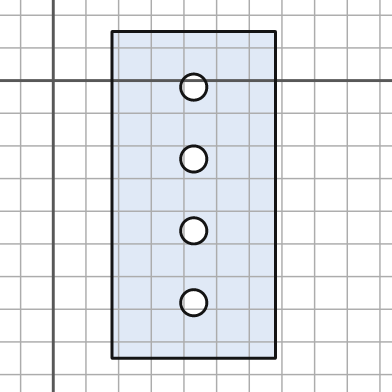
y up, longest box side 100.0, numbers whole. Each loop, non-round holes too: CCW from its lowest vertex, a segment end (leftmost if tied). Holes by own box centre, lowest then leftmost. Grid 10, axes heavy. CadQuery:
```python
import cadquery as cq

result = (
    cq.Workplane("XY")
    .moveTo(18.0, -85.0)
    .lineTo(68.0, -85.0)
    .lineTo(68.0, 15.0)
    .lineTo(18.0, 15.0)
    .close()
    .moveTo(43.0, -68.0)
    .circle(4.0)
    .moveTo(43.0, -46.0)
    .circle(4.0)
    .moveTo(43.0, -24.0)
    .circle(4.0)
    .moveTo(43.0, -2.0)
    .circle(4.0)
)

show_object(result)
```